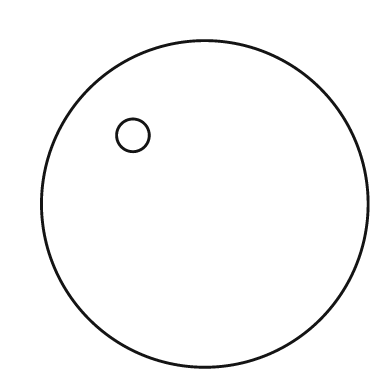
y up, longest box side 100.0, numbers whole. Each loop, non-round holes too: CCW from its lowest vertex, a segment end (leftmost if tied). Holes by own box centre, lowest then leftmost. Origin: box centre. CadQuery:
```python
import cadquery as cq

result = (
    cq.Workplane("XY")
    .moveTo(0.0, 0.0)
    .circle(50.0)
    .moveTo(-22.0, 21.0)
    .circle(5.0)
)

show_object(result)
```